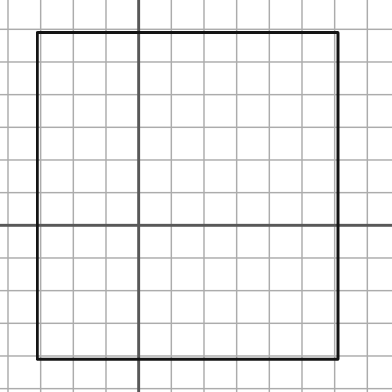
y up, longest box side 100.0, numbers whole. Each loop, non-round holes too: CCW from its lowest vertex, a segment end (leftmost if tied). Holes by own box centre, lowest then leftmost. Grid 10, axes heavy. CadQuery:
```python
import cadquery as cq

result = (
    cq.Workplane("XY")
    .moveTo(-31.0, -41.0)
    .lineTo(61.0, -41.0)
    .lineTo(61.0, 59.0)
    .lineTo(-31.0, 59.0)
    .close()
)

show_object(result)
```